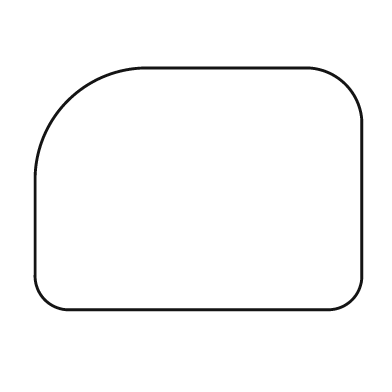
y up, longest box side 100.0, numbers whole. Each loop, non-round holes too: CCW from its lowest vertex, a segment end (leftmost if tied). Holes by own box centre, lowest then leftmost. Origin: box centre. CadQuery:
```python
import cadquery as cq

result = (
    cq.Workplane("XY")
    .moveTo(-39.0, -37.0)
    .lineTo(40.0, -37.0)
    .threePointArc((47.0, -34.0), (50.0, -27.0))
    .lineTo(50.0, 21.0)
    .threePointArc((45.0, 32.0), (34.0, 37.0))
    .lineTo(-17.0, 37.0)
    .threePointArc((-40.0, 27.0), (-50.0, 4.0))
    .lineTo(-50.0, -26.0)
    .threePointArc((-47.0, -34.0), (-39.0, -37.0))
    .close()
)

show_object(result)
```